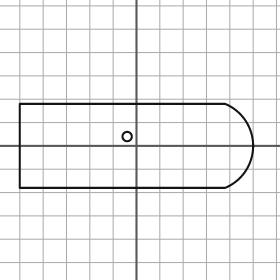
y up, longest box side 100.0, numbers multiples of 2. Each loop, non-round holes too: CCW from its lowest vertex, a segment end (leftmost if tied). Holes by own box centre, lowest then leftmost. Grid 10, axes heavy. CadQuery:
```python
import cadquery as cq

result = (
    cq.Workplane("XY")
    .moveTo(-50.0, -18.0)
    .lineTo(38.0, -18.0)
    .threePointArc((50.0, 0.0), (38.0, 18.0))
    .lineTo(-50.0, 18.0)
    .close()
    .moveTo(-4.0, 4.0)
    .circle(2.0)
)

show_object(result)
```